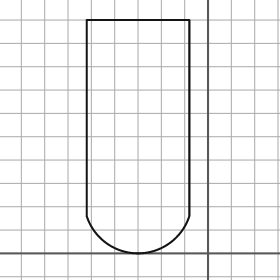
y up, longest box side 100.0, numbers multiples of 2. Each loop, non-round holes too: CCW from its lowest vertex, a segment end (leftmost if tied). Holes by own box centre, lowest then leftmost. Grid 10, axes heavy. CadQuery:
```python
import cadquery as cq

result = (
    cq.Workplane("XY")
    .moveTo(-52.0, 16.0)
    .threePointArc((-30.0, 0.0), (-8.0, 16.0))
    .lineTo(-8.0, 100.0)
    .lineTo(-52.0, 100.0)
    .close()
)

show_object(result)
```